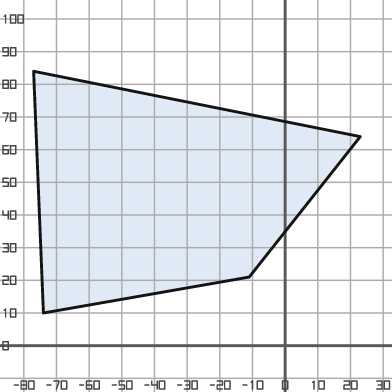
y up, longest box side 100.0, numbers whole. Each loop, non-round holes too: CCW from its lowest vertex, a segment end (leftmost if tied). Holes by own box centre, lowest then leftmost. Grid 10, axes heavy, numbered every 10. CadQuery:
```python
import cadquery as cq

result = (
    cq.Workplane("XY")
    .moveTo(-74.0, 10.0)
    .lineTo(-11.0, 21.0)
    .lineTo(23.0, 64.0)
    .lineTo(-77.0, 84.0)
    .close()
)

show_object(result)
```